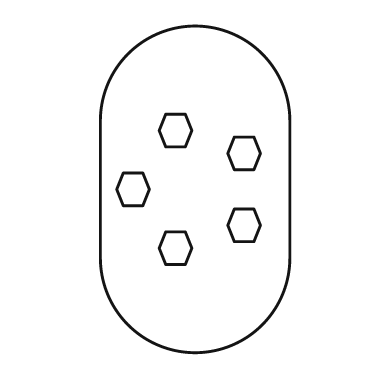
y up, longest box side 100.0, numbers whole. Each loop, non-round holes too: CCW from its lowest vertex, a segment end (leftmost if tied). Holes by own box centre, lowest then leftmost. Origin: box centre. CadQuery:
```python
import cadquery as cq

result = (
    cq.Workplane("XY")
    .moveTo(-29.0, -21.0)
    .threePointArc((0.0, -50.0), (29.0, -21.0))
    .lineTo(29.0, 21.0)
    .threePointArc((0.0, 50.0), (-29.0, 21.0))
    .close()
    .moveTo(-9.0, -23.0)
    .lineTo(-3.0, -23.0)
    .lineTo(-1.0, -18.0)
    .lineTo(-3.0, -13.0)
    .lineTo(-9.0, -13.0)
    .lineTo(-11.0, -18.0)
    .close()
    .moveTo(12.0, -16.0)
    .lineTo(18.0, -16.0)
    .lineTo(20.0, -11.0)
    .lineTo(18.0, -6.0)
    .lineTo(12.0, -6.0)
    .lineTo(10.0, -11.0)
    .close()
    .moveTo(-22.0, -5.0)
    .lineTo(-16.0, -5.0)
    .lineTo(-14.0, 0.0)
    .lineTo(-16.0, 5.0)
    .lineTo(-22.0, 5.0)
    .lineTo(-24.0, 0.0)
    .close()
    .moveTo(12.0, 6.0)
    .lineTo(18.0, 6.0)
    .lineTo(20.0, 11.0)
    .lineTo(18.0, 16.0)
    .lineTo(12.0, 16.0)
    .lineTo(10.0, 11.0)
    .close()
    .moveTo(-9.0, 13.0)
    .lineTo(-3.0, 13.0)
    .lineTo(-1.0, 18.0)
    .lineTo(-3.0, 23.0)
    .lineTo(-9.0, 23.0)
    .lineTo(-11.0, 18.0)
    .close()
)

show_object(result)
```